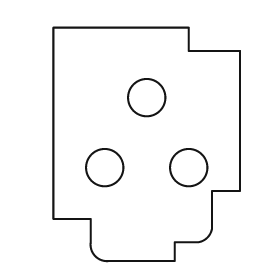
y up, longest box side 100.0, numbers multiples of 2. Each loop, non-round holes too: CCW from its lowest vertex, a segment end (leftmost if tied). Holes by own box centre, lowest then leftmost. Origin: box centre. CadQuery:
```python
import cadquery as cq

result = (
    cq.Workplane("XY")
    .moveTo(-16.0, -50.0)
    .lineTo(12.0, -50.0)
    .lineTo(12.0, -42.0)
    .lineTo(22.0, -42.0)
    .threePointArc((26.0, -40.0), (28.0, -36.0))
    .lineTo(28.0, -20.0)
    .lineTo(40.0, -20.0)
    .lineTo(40.0, 40.0)
    .lineTo(18.0, 40.0)
    .lineTo(18.0, 50.0)
    .lineTo(-40.0, 50.0)
    .lineTo(-40.0, -32.0)
    .lineTo(-24.0, -32.0)
    .lineTo(-24.0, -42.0)
    .threePointArc((-22.0, -48.0), (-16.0, -50.0))
    .close()
    .moveTo(-18.0, -10.0)
    .circle(8.0)
    .moveTo(18.0, -10.0)
    .circle(8.0)
    .moveTo(0.0, 20.0)
    .circle(8.0)
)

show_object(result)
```